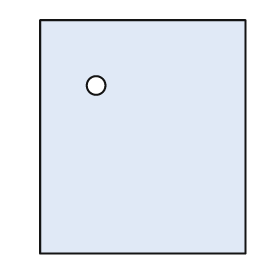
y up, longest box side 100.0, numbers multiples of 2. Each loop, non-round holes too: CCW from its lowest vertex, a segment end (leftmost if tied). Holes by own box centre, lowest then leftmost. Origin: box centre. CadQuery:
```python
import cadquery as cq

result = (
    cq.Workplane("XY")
    .moveTo(-44.0, -50.0)
    .lineTo(44.0, -50.0)
    .lineTo(44.0, 50.0)
    .lineTo(-44.0, 50.0)
    .close()
    .moveTo(-20.0, 22.0)
    .circle(4.0)
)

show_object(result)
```